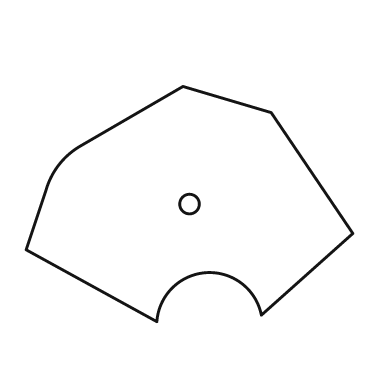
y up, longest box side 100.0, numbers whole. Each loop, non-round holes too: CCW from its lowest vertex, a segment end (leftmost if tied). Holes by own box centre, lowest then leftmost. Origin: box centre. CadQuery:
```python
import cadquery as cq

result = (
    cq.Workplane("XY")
    .moveTo(-10.0, -36.0)
    .threePointArc((5.0, -21.0), (22.0, -34.0))
    .lineTo(50.0, -9.0)
    .lineTo(25.0, 28.0)
    .lineTo(-2.0, 36.0)
    .lineTo(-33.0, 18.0)
    .threePointArc((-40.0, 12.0), (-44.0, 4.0))
    .lineTo(-50.0, -14.0)
    .close()
    .moveTo(0.0, 0.0)
    .circle(3.0)
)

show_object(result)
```